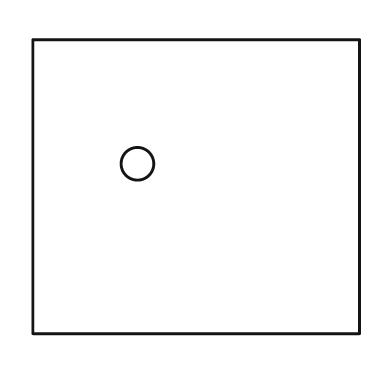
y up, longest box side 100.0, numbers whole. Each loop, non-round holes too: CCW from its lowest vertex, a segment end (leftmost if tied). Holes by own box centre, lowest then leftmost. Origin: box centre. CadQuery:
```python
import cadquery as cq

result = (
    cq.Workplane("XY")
    .moveTo(-50.0, -45.0)
    .lineTo(50.0, -45.0)
    .lineTo(50.0, 45.0)
    .lineTo(-50.0, 45.0)
    .close()
    .moveTo(-18.0, 7.0)
    .circle(5.0)
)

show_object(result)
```